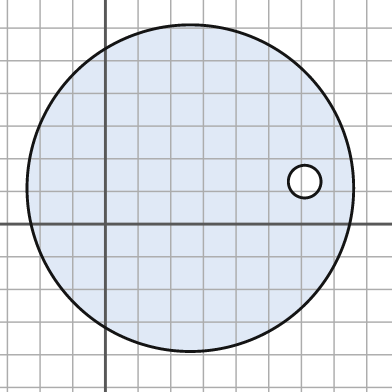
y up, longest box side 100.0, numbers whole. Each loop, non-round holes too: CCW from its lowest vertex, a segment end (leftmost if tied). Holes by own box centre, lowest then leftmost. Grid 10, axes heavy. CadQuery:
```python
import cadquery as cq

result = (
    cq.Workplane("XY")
    .moveTo(26.0, 11.0)
    .circle(50.0)
    .moveTo(61.0, 13.0)
    .circle(5.0)
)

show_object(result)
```